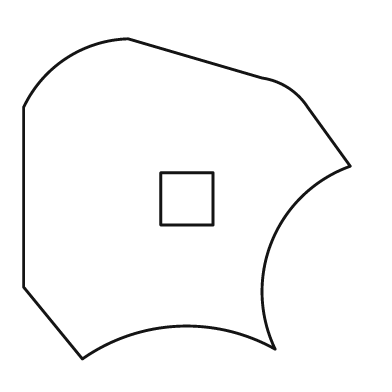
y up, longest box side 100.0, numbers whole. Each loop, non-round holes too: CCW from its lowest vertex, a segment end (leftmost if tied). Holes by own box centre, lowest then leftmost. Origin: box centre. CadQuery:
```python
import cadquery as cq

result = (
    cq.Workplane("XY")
    .moveTo(-32.0, -49.0)
    .threePointArc((-3.0, -39.0), (27.0, -46.0))
    .threePointArc((26.0, -13.0), (50.0, 10.0))
    .lineTo(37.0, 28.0)
    .threePointArc((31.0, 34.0), (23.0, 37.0))
    .lineTo(-18.0, 49.0)
    .threePointArc((-37.0, 43.0), (-50.0, 28.0))
    .lineTo(-50.0, -27.0)
    .close()
    .moveTo(-8.0, -8.0)
    .lineTo(8.0, -8.0)
    .lineTo(8.0, 8.0)
    .lineTo(-8.0, 8.0)
    .close()
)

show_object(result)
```